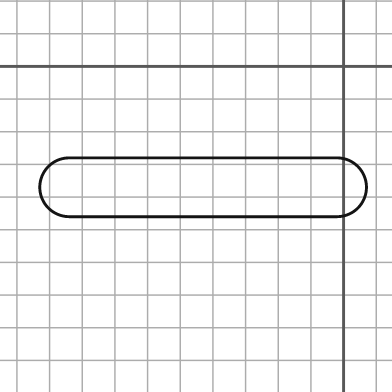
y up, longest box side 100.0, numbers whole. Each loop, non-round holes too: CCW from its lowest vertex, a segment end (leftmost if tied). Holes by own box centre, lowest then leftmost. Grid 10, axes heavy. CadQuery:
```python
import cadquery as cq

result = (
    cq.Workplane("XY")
    .moveTo(-84.0, -46.0)
    .lineTo(-2.0, -46.0)
    .threePointArc((7.0, -37.0), (-2.0, -28.0))
    .lineTo(-84.0, -28.0)
    .threePointArc((-93.0, -37.0), (-84.0, -46.0))
    .close()
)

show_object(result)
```